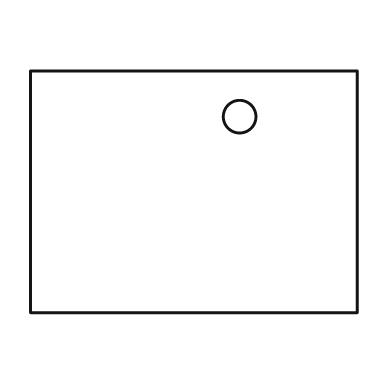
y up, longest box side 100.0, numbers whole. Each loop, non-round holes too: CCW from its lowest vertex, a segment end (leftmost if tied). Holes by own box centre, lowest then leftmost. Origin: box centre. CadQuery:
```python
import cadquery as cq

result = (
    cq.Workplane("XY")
    .moveTo(-50.0, -37.0)
    .lineTo(50.0, -37.0)
    .lineTo(50.0, 37.0)
    .lineTo(-50.0, 37.0)
    .close()
    .moveTo(14.0, 23.0)
    .circle(5.0)
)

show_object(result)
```